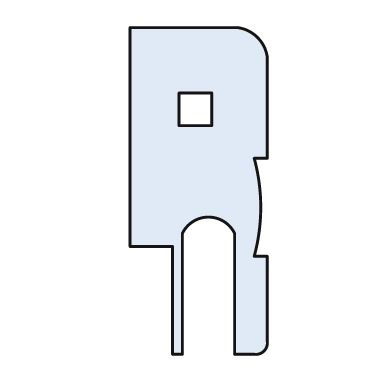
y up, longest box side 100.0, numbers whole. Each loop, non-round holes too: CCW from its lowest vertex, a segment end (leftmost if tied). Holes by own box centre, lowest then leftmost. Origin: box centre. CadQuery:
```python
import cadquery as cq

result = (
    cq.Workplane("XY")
    .moveTo(-8.0, -50.0)
    .lineTo(-5.0, -50.0)
    .lineTo(-5.0, -13.0)
    .threePointArc((3.0, -8.0), (11.0, -13.0))
    .lineTo(11.0, -50.0)
    .lineTo(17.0, -50.0)
    .threePointArc((20.0, -49.0), (21.0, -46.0))
    .lineTo(21.0, -20.0)
    .lineTo(17.0, -20.0)
    .threePointArc((19.0, -5.0), (17.0, 10.0))
    .lineTo(21.0, 10.0)
    .lineTo(21.0, 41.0)
    .threePointArc((18.0, 47.0), (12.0, 50.0))
    .lineTo(-21.0, 50.0)
    .lineTo(-21.0, -17.0)
    .lineTo(-8.0, -17.0)
    .close()
    .moveTo(-6.0, 20.0)
    .lineTo(4.0, 20.0)
    .lineTo(4.0, 30.0)
    .lineTo(-6.0, 30.0)
    .close()
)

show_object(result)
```